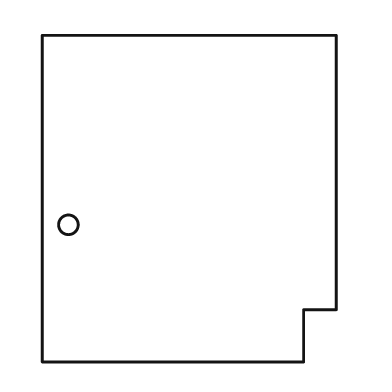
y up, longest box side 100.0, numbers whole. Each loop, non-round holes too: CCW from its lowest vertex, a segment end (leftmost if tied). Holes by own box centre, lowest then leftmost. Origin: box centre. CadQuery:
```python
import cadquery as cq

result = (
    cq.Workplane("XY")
    .moveTo(-45.0, -50.0)
    .lineTo(35.0, -50.0)
    .lineTo(35.0, -34.0)
    .lineTo(45.0, -34.0)
    .lineTo(45.0, 50.0)
    .lineTo(-45.0, 50.0)
    .close()
    .moveTo(-37.0, -8.0)
    .circle(3.0)
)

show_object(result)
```